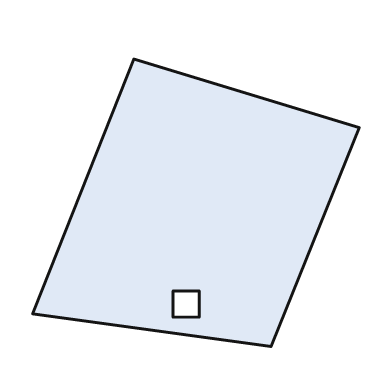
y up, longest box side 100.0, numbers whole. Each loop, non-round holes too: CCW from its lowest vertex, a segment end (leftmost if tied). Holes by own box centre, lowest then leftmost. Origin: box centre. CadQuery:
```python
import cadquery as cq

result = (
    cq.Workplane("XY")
    .moveTo(23.0, -44.0)
    .lineTo(50.0, 23.0)
    .lineTo(-19.0, 44.0)
    .lineTo(-50.0, -34.0)
    .close()
    .moveTo(-7.0, -35.0)
    .lineTo(1.0, -35.0)
    .lineTo(1.0, -27.0)
    .lineTo(-7.0, -27.0)
    .close()
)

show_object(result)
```